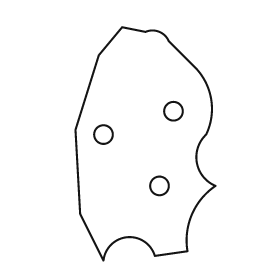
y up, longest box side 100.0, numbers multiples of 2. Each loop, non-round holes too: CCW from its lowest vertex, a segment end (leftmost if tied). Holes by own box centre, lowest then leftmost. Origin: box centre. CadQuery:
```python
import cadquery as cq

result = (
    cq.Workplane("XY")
    .moveTo(-18.0, -50.0)
    .threePointArc((-8.0, -40.0), (4.0, -48.0))
    .lineTo(18.0, -46.0)
    .threePointArc((20.0, -30.0), (30.0, -18.0))
    .threePointArc((22.0, -8.0), (26.0, 4.0))
    .threePointArc((28.0, 20.0), (20.0, 34.0))
    .lineTo(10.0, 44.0)
    .threePointArc((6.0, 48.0), (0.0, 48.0))
    .lineTo(-10.0, 50.0)
    .lineTo(-20.0, 38.0)
    .lineTo(-30.0, 6.0)
    .lineTo(-28.0, -30.0)
    .close()
    .moveTo(6.0, -18.0)
    .circle(4.0)
    .moveTo(-18.0, 4.0)
    .circle(4.0)
    .moveTo(12.0, 14.0)
    .circle(4.0)
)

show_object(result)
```